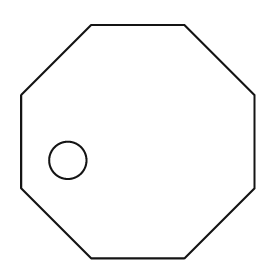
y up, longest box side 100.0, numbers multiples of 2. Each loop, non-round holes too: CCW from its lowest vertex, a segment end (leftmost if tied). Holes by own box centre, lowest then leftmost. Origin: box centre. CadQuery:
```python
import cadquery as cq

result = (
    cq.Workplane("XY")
    .moveTo(-20.0, -50.0)
    .lineTo(20.0, -50.0)
    .lineTo(50.0, -20.0)
    .lineTo(50.0, 20.0)
    .lineTo(20.0, 50.0)
    .lineTo(-20.0, 50.0)
    .lineTo(-50.0, 20.0)
    .lineTo(-50.0, -20.0)
    .close()
    .moveTo(-30.0, -8.0)
    .circle(8.0)
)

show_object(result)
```